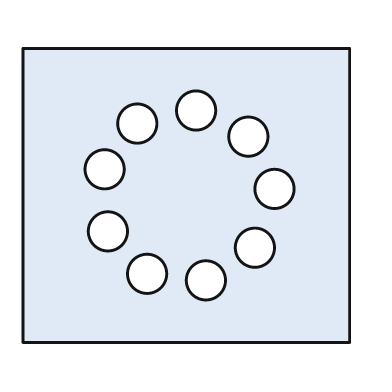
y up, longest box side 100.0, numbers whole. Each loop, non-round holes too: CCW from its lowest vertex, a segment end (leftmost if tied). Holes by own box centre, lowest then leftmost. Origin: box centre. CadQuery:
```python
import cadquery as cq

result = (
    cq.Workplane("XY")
    .moveTo(-50.0, -45.0)
    .lineTo(50.0, -45.0)
    .lineTo(50.0, 45.0)
    .lineTo(-50.0, 45.0)
    .close()
    .moveTo(6.0, -26.0)
    .circle(6.0)
    .moveTo(-12.0, -24.0)
    .circle(6.0)
    .moveTo(21.0, -16.0)
    .circle(6.0)
    .moveTo(-24.0, -11.0)
    .circle(6.0)
    .moveTo(27.0, 2.0)
    .circle(6.0)
    .moveTo(-25.0, 8.0)
    .circle(6.0)
    .moveTo(19.0, 18.0)
    .circle(6.0)
    .moveTo(-15.0, 22.0)
    .circle(6.0)
    .moveTo(3.0, 26.0)
    .circle(6.0)
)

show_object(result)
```